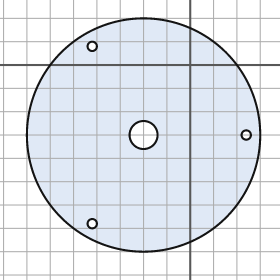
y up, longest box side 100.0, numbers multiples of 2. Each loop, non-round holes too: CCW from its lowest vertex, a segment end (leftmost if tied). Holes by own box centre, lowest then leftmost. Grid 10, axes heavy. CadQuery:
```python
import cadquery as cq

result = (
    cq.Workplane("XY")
    .moveTo(-20.0, -30.0)
    .circle(50.0)
    .moveTo(-42.0, -68.0)
    .circle(2.0)
    .moveTo(-20.0, -30.0)
    .circle(6.0)
    .moveTo(24.0, -30.0)
    .circle(2.0)
    .moveTo(-42.0, 8.0)
    .circle(2.0)
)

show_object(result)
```